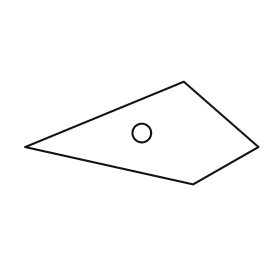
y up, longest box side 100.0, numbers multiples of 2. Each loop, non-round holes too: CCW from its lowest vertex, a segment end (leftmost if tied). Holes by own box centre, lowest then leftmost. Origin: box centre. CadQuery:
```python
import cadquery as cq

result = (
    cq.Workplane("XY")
    .moveTo(22.0, -22.0)
    .lineTo(50.0, -6.0)
    .lineTo(18.0, 22.0)
    .lineTo(-50.0, -6.0)
    .close()
    .moveTo(0.0, 0.0)
    .circle(4.0)
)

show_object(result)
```